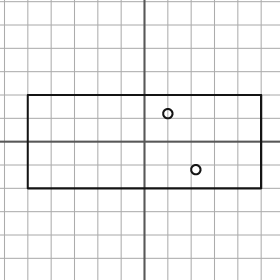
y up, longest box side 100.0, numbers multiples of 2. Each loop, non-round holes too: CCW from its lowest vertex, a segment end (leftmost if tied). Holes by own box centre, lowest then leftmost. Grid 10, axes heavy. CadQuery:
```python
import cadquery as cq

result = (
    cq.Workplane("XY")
    .moveTo(-50.0, -20.0)
    .lineTo(50.0, -20.0)
    .lineTo(50.0, 20.0)
    .lineTo(-50.0, 20.0)
    .close()
    .moveTo(22.0, -12.0)
    .circle(2.0)
    .moveTo(10.0, 12.0)
    .circle(2.0)
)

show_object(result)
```